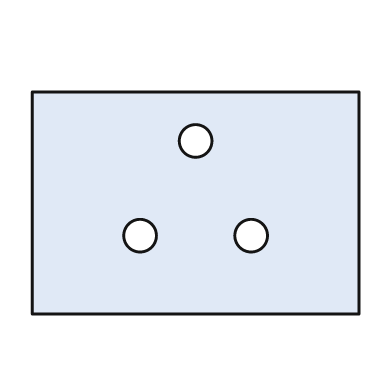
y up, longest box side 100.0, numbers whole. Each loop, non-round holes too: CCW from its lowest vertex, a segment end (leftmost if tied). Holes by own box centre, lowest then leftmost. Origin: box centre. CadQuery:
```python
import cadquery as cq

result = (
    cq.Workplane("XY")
    .moveTo(-50.0, -34.0)
    .lineTo(50.0, -34.0)
    .lineTo(50.0, 34.0)
    .lineTo(-50.0, 34.0)
    .close()
    .moveTo(-17.0, -10.0)
    .circle(5.0)
    .moveTo(17.0, -10.0)
    .circle(5.0)
    .moveTo(0.0, 19.0)
    .circle(5.0)
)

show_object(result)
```